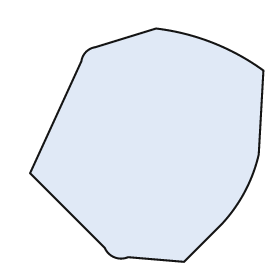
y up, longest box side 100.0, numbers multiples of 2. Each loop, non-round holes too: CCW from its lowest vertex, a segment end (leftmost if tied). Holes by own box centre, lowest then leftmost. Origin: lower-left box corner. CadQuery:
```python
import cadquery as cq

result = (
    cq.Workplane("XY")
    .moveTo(66.0, 0.0)
    .lineTo(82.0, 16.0)
    .threePointArc((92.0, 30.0), (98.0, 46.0))
    .lineTo(100.0, 82.0)
    .threePointArc((78.0, 94.0), (54.0, 100.0))
    .lineTo(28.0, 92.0)
    .threePointArc((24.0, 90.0), (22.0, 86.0))
    .lineTo(0.0, 38.0)
    .lineTo(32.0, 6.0)
    .threePointArc((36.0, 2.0), (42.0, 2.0))
    .close()
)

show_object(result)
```